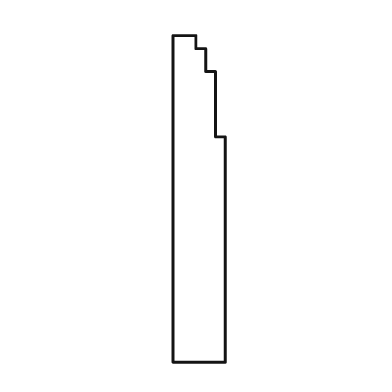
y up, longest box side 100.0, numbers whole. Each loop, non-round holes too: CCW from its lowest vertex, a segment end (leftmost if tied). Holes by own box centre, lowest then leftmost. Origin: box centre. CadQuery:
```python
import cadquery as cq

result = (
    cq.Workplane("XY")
    .moveTo(-8.0, -50.0)
    .lineTo(8.0, -50.0)
    .lineTo(8.0, 19.0)
    .lineTo(5.0, 19.0)
    .lineTo(5.0, 39.0)
    .lineTo(2.0, 39.0)
    .lineTo(2.0, 46.0)
    .lineTo(-1.0, 46.0)
    .lineTo(-1.0, 50.0)
    .lineTo(-8.0, 50.0)
    .close()
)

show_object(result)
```